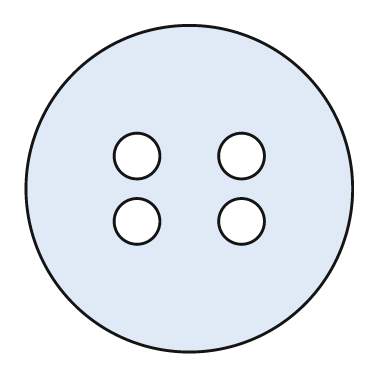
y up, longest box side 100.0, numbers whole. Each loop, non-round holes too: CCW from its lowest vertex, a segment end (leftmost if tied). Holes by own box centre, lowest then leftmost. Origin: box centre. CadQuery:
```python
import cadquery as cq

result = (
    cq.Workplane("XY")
    .moveTo(0.0, 0.0)
    .circle(50.0)
    .moveTo(-16.0, -10.0)
    .circle(7.0)
    .moveTo(16.0, -10.0)
    .circle(7.0)
    .moveTo(-16.0, 10.0)
    .circle(7.0)
    .moveTo(16.0, 10.0)
    .circle(7.0)
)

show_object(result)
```